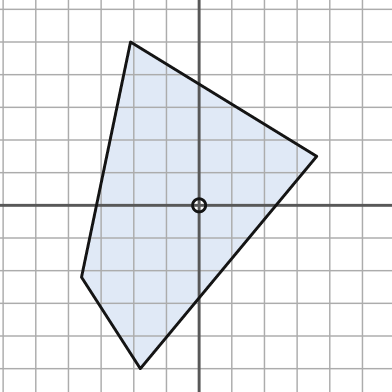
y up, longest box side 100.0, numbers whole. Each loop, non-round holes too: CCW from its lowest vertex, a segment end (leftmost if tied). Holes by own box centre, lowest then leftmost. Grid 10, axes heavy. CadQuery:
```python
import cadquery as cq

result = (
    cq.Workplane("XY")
    .moveTo(-18.0, -50.0)
    .lineTo(36.0, 15.0)
    .lineTo(-21.0, 50.0)
    .lineTo(-36.0, -22.0)
    .close()
    .moveTo(0.0, 0.0)
    .circle(2.0)
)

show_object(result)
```